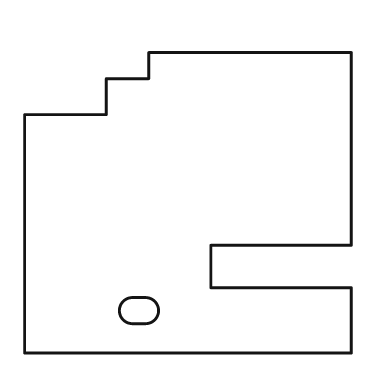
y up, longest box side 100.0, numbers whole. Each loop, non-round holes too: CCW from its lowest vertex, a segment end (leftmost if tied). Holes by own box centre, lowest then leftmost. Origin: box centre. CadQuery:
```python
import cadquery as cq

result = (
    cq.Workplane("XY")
    .moveTo(-50.0, -46.0)
    .lineTo(50.0, -46.0)
    .lineTo(50.0, -26.0)
    .lineTo(7.0, -26.0)
    .lineTo(7.0, -13.0)
    .lineTo(50.0, -13.0)
    .lineTo(50.0, 46.0)
    .lineTo(-12.0, 46.0)
    .lineTo(-12.0, 38.0)
    .lineTo(-25.0, 38.0)
    .lineTo(-25.0, 27.0)
    .lineTo(-50.0, 27.0)
    .close()
    .moveTo(-17.0, -37.0)
    .lineTo(-13.0, -37.0)
    .threePointArc((-9.0, -33.0), (-13.0, -29.0))
    .lineTo(-17.0, -29.0)
    .threePointArc((-21.0, -33.0), (-17.0, -37.0))
    .close()
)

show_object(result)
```